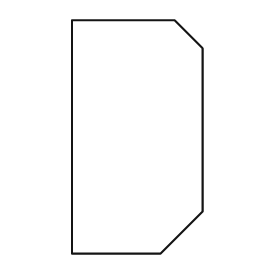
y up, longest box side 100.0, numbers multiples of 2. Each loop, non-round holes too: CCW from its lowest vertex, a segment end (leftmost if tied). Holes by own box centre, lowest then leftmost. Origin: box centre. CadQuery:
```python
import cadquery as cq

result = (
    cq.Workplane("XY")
    .moveTo(-28.0, -50.0)
    .lineTo(10.0, -50.0)
    .lineTo(28.0, -32.0)
    .lineTo(28.0, 38.0)
    .lineTo(16.0, 50.0)
    .lineTo(-28.0, 50.0)
    .close()
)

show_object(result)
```